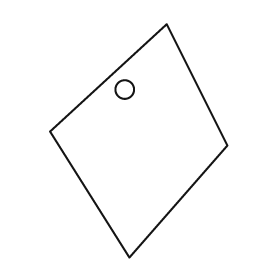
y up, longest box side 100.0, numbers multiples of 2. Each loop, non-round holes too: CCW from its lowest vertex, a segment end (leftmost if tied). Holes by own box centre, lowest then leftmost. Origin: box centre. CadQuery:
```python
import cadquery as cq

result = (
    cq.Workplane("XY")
    .moveTo(-4.0, -50.0)
    .lineTo(38.0, -2.0)
    .lineTo(12.0, 50.0)
    .lineTo(-38.0, 4.0)
    .close()
    .moveTo(-6.0, 22.0)
    .circle(4.0)
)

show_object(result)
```